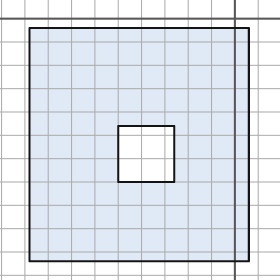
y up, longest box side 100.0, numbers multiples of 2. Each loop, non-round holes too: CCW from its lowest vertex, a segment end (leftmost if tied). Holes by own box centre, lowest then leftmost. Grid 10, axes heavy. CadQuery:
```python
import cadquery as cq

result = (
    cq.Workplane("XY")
    .moveTo(-88.0, -104.0)
    .lineTo(6.0, -104.0)
    .lineTo(6.0, -4.0)
    .lineTo(-88.0, -4.0)
    .close()
    .moveTo(-50.0, -70.0)
    .lineTo(-26.0, -70.0)
    .lineTo(-26.0, -46.0)
    .lineTo(-50.0, -46.0)
    .close()
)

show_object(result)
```